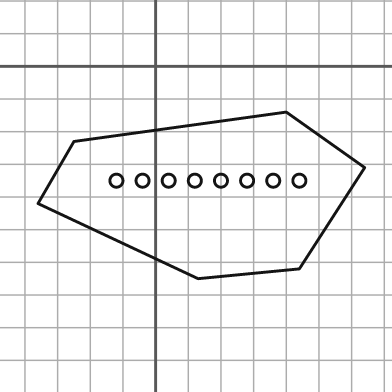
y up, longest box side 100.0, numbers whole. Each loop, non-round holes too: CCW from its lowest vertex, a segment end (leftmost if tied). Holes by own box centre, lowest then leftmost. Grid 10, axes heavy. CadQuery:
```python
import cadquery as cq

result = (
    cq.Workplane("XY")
    .moveTo(13.0, -65.0)
    .lineTo(44.0, -62.0)
    .lineTo(64.0, -31.0)
    .lineTo(40.0, -14.0)
    .lineTo(-25.0, -23.0)
    .lineTo(-36.0, -42.0)
    .close()
    .moveTo(-12.0, -35.0)
    .circle(2.0)
    .moveTo(-4.0, -35.0)
    .circle(2.0)
    .moveTo(4.0, -35.0)
    .circle(2.0)
    .moveTo(12.0, -35.0)
    .circle(2.0)
    .moveTo(20.0, -35.0)
    .circle(2.0)
    .moveTo(28.0, -35.0)
    .circle(2.0)
    .moveTo(36.0, -35.0)
    .circle(2.0)
    .moveTo(44.0, -35.0)
    .circle(2.0)
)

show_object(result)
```